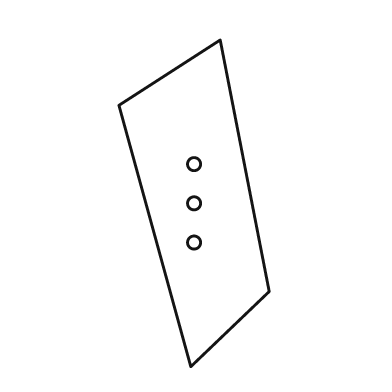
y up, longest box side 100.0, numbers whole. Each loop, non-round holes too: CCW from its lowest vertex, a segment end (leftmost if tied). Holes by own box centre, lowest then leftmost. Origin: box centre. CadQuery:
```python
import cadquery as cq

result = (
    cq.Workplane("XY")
    .moveTo(-1.0, -50.0)
    .lineTo(23.0, -27.0)
    .lineTo(8.0, 50.0)
    .lineTo(-23.0, 30.0)
    .close()
    .moveTo(0.0, -12.0)
    .circle(2.0)
    .moveTo(0.0, 0.0)
    .circle(2.0)
    .moveTo(0.0, 12.0)
    .circle(2.0)
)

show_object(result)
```